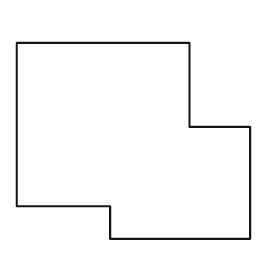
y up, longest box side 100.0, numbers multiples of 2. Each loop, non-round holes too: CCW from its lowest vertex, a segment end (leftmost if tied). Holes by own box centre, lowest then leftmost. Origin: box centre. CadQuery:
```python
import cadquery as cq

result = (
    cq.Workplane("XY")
    .moveTo(-10.0, -42.0)
    .lineTo(50.0, -42.0)
    .lineTo(50.0, 6.0)
    .lineTo(24.0, 6.0)
    .lineTo(24.0, 42.0)
    .lineTo(-50.0, 42.0)
    .lineTo(-50.0, -28.0)
    .lineTo(-10.0, -28.0)
    .close()
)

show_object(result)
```